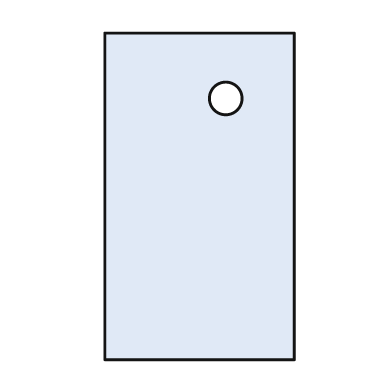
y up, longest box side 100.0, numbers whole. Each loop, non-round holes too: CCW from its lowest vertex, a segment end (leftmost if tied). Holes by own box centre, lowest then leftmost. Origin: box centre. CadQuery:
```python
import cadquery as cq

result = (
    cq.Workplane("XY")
    .moveTo(-29.0, -50.0)
    .lineTo(29.0, -50.0)
    .lineTo(29.0, 50.0)
    .lineTo(-29.0, 50.0)
    .close()
    .moveTo(8.0, 30.0)
    .circle(5.0)
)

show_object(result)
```